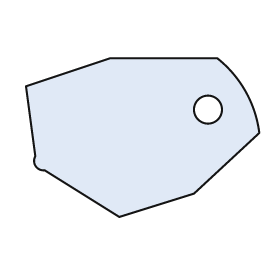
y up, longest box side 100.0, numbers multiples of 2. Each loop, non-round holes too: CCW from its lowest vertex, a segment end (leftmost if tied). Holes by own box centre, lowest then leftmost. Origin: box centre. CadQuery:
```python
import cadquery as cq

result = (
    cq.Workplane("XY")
    .moveTo(-10.0, -34.0)
    .lineTo(22.0, -24.0)
    .lineTo(50.0, 2.0)
    .threePointArc((44.0, 20.0), (32.0, 34.0))
    .lineTo(-14.0, 34.0)
    .lineTo(-50.0, 22.0)
    .lineTo(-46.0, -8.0)
    .threePointArc((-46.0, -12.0), (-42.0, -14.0))
    .close()
    .moveTo(28.0, 12.0)
    .circle(6.0)
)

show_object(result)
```